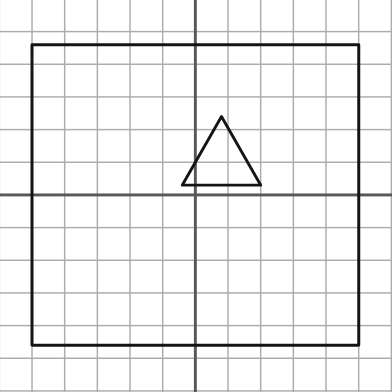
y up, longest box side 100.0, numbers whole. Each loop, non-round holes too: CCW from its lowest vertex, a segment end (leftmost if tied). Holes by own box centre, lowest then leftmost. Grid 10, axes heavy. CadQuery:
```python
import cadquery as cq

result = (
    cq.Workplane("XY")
    .moveTo(-50.0, -46.0)
    .lineTo(50.0, -46.0)
    .lineTo(50.0, 46.0)
    .lineTo(-50.0, 46.0)
    .close()
    .moveTo(-4.0, 3.0)
    .lineTo(20.0, 3.0)
    .lineTo(8.0, 24.0)
    .close()
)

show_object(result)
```